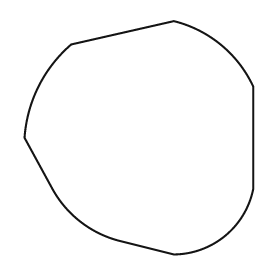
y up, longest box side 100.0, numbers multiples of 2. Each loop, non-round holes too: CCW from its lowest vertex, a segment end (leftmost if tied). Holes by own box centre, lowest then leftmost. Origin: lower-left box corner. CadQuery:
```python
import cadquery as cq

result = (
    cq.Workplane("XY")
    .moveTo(64.0, 0.0)
    .threePointArc((86.0, 8.0), (98.0, 28.0))
    .lineTo(98.0, 72.0)
    .threePointArc((84.0, 90.0), (64.0, 100.0))
    .lineTo(20.0, 90.0)
    .threePointArc((6.0, 72.0), (0.0, 50.0))
    .lineTo(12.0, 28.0)
    .threePointArc((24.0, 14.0), (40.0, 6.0))
    .close()
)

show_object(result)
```